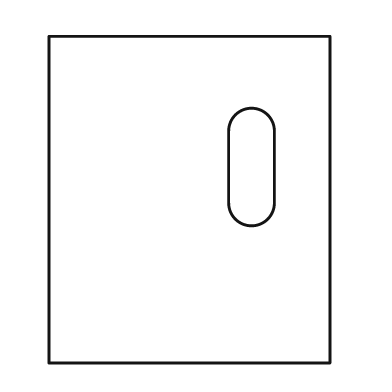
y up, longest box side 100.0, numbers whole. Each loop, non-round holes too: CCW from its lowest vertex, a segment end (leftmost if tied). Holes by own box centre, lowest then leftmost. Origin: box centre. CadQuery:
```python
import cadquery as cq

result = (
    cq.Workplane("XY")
    .moveTo(-43.0, -50.0)
    .lineTo(43.0, -50.0)
    .lineTo(43.0, 50.0)
    .lineTo(-43.0, 50.0)
    .close()
    .moveTo(12.0, -1.0)
    .threePointArc((19.0, -8.0), (26.0, -1.0))
    .lineTo(26.0, 21.0)
    .threePointArc((19.0, 28.0), (12.0, 21.0))
    .close()
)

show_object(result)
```